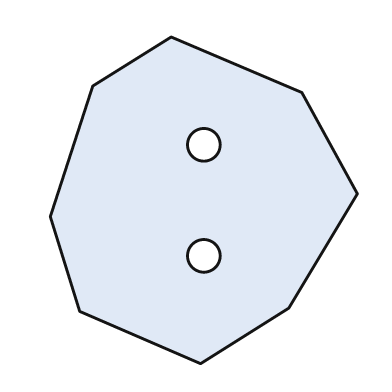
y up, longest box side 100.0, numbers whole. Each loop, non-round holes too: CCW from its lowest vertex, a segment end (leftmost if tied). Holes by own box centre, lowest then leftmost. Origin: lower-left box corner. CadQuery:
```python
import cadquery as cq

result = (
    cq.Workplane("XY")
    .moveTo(46.0, 0.0)
    .lineTo(73.0, 17.0)
    .lineTo(94.0, 52.0)
    .lineTo(77.0, 83.0)
    .lineTo(37.0, 100.0)
    .lineTo(13.0, 85.0)
    .lineTo(0.0, 45.0)
    .lineTo(9.0, 16.0)
    .close()
    .moveTo(47.0, 33.0)
    .circle(5.0)
    .moveTo(47.0, 67.0)
    .circle(5.0)
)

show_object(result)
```